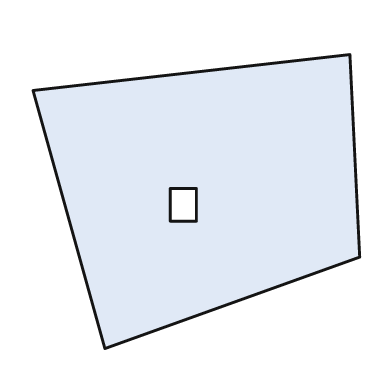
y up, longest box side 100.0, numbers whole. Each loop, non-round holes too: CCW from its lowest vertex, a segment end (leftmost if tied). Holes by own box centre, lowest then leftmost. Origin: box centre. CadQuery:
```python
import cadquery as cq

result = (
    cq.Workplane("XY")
    .moveTo(-28.0, -45.0)
    .lineTo(50.0, -17.0)
    .lineTo(47.0, 45.0)
    .lineTo(-50.0, 34.0)
    .close()
    .moveTo(-8.0, -6.0)
    .lineTo(0.0, -6.0)
    .lineTo(0.0, 4.0)
    .lineTo(-8.0, 4.0)
    .close()
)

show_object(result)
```